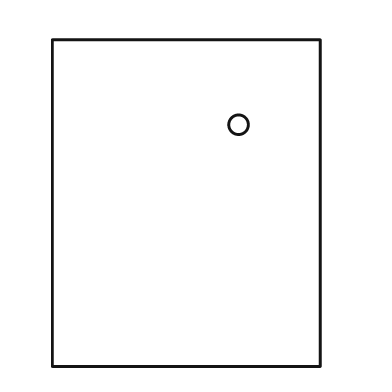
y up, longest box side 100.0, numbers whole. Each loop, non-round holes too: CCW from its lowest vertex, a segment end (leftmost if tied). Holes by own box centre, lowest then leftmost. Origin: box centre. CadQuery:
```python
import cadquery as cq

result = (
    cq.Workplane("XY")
    .moveTo(-41.0, -50.0)
    .lineTo(41.0, -50.0)
    .lineTo(41.0, 50.0)
    .lineTo(-41.0, 50.0)
    .close()
    .moveTo(16.0, 24.0)
    .circle(3.0)
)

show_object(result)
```